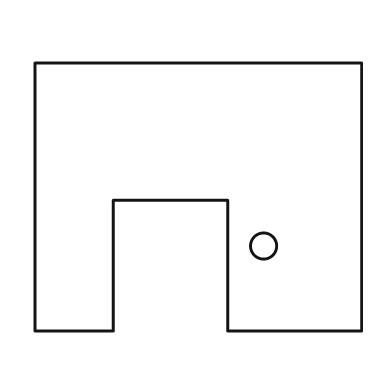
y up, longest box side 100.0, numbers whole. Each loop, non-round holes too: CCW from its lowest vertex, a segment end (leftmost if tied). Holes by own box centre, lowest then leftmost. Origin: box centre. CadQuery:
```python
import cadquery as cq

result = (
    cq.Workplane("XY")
    .moveTo(-50.0, -41.0)
    .lineTo(-26.0, -41.0)
    .lineTo(-26.0, -1.0)
    .lineTo(9.0, -1.0)
    .lineTo(9.0, -41.0)
    .lineTo(50.0, -41.0)
    .lineTo(50.0, 41.0)
    .lineTo(-50.0, 41.0)
    .close()
    .moveTo(20.0, -15.0)
    .circle(4.0)
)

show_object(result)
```